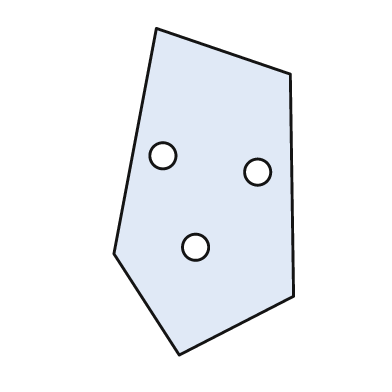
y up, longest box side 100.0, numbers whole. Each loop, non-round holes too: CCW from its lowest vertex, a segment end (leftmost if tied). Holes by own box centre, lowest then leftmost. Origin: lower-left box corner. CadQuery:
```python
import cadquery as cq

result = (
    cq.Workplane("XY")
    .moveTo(20.0, 0.0)
    .lineTo(55.0, 18.0)
    .lineTo(54.0, 86.0)
    .lineTo(13.0, 100.0)
    .lineTo(0.0, 31.0)
    .close()
    .moveTo(25.0, 33.0)
    .circle(4.0)
    .moveTo(44.0, 56.0)
    .circle(4.0)
    .moveTo(15.0, 61.0)
    .circle(4.0)
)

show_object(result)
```